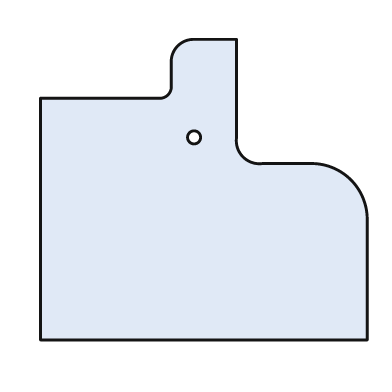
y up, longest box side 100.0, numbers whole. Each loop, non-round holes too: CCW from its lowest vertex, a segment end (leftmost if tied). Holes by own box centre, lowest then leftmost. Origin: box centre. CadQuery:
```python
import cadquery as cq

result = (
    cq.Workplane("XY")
    .moveTo(-50.0, -46.0)
    .lineTo(50.0, -46.0)
    .lineTo(50.0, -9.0)
    .threePointArc((45.0, 3.0), (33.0, 8.0))
    .lineTo(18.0, 8.0)
    .threePointArc((12.0, 10.0), (10.0, 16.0))
    .lineTo(10.0, 46.0)
    .lineTo(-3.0, 46.0)
    .threePointArc((-8.0, 44.0), (-10.0, 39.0))
    .lineTo(-10.0, 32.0)
    .threePointArc((-11.0, 29.0), (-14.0, 28.0))
    .lineTo(-50.0, 28.0)
    .close()
    .moveTo(-3.0, 16.0)
    .circle(2.0)
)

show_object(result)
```